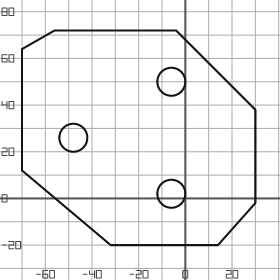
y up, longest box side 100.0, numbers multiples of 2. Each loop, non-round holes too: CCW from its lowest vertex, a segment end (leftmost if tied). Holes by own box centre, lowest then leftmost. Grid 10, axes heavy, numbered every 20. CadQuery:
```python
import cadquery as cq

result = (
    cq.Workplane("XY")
    .moveTo(-32.0, -20.0)
    .lineTo(14.0, -20.0)
    .lineTo(30.0, -2.0)
    .lineTo(30.0, 38.0)
    .lineTo(-4.0, 72.0)
    .lineTo(-56.0, 72.0)
    .lineTo(-70.0, 64.0)
    .lineTo(-70.0, 12.0)
    .close()
    .moveTo(-6.0, 2.0)
    .circle(6.0)
    .moveTo(-48.0, 26.0)
    .circle(6.0)
    .moveTo(-6.0, 50.0)
    .circle(6.0)
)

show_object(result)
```